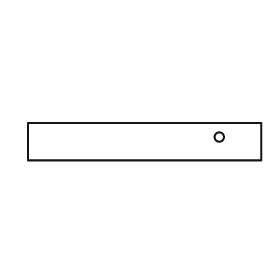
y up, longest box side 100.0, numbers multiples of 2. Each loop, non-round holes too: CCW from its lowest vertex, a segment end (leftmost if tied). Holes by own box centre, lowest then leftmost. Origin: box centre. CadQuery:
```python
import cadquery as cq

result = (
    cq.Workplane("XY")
    .moveTo(-50.0, -8.0)
    .lineTo(50.0, -8.0)
    .lineTo(50.0, 8.0)
    .lineTo(-50.0, 8.0)
    .close()
    .moveTo(32.0, 2.0)
    .circle(2.0)
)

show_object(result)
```